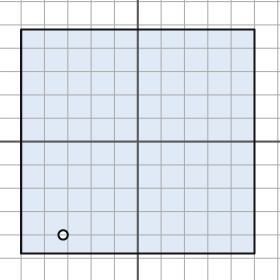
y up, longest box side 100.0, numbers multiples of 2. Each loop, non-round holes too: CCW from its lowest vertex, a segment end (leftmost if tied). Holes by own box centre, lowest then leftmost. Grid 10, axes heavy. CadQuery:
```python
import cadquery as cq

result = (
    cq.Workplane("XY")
    .moveTo(-50.0, -48.0)
    .lineTo(50.0, -48.0)
    .lineTo(50.0, 48.0)
    .lineTo(-50.0, 48.0)
    .close()
    .moveTo(-32.0, -40.0)
    .circle(2.0)
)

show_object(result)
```